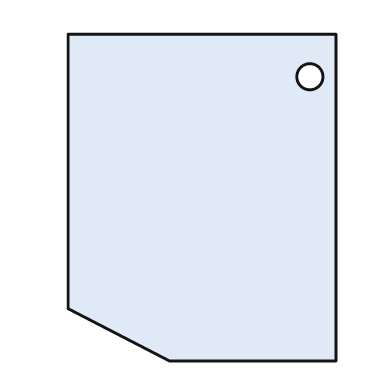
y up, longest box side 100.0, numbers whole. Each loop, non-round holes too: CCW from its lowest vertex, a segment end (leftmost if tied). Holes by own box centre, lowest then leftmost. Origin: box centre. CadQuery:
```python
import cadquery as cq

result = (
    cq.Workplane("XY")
    .moveTo(-10.0, -50.0)
    .lineTo(41.0, -50.0)
    .lineTo(41.0, 50.0)
    .lineTo(-41.0, 50.0)
    .lineTo(-41.0, -34.0)
    .close()
    .moveTo(33.0, 37.0)
    .circle(4.0)
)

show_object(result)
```